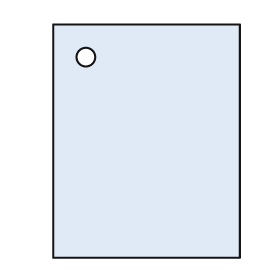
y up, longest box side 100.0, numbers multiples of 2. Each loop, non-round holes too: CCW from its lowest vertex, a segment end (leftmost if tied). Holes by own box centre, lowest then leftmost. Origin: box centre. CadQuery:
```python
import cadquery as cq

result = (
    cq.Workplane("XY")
    .moveTo(-40.0, -50.0)
    .lineTo(40.0, -50.0)
    .lineTo(40.0, 50.0)
    .lineTo(-40.0, 50.0)
    .close()
    .moveTo(-26.0, 36.0)
    .circle(4.0)
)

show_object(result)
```